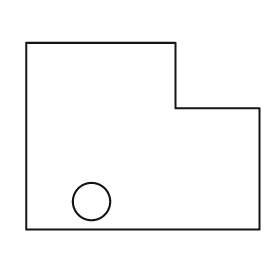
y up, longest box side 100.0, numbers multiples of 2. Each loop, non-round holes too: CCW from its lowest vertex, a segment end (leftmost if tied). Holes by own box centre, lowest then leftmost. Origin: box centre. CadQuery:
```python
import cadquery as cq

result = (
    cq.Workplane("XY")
    .moveTo(-50.0, -40.0)
    .lineTo(50.0, -40.0)
    .lineTo(50.0, 12.0)
    .lineTo(14.0, 12.0)
    .lineTo(14.0, 40.0)
    .lineTo(-50.0, 40.0)
    .close()
    .moveTo(-22.0, -28.0)
    .circle(8.0)
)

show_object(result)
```